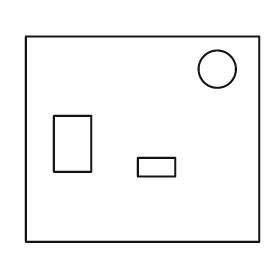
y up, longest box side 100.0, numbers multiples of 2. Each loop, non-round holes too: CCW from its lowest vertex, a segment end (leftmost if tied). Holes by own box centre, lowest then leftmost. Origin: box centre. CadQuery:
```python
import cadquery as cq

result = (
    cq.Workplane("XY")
    .moveTo(-50.0, -44.0)
    .lineTo(50.0, -44.0)
    .lineTo(50.0, 44.0)
    .lineTo(-50.0, 44.0)
    .close()
    .moveTo(-2.0, -16.0)
    .lineTo(14.0, -16.0)
    .lineTo(14.0, -8.0)
    .lineTo(-2.0, -8.0)
    .close()
    .moveTo(-38.0, -14.0)
    .lineTo(-22.0, -14.0)
    .lineTo(-22.0, 10.0)
    .lineTo(-38.0, 10.0)
    .close()
    .moveTo(32.0, 30.0)
    .circle(8.0)
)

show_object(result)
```